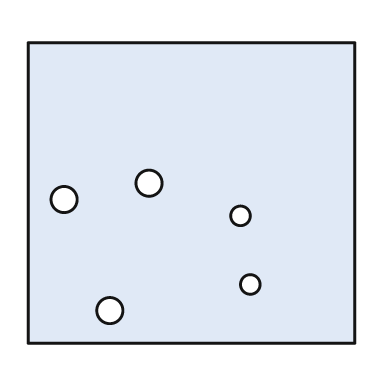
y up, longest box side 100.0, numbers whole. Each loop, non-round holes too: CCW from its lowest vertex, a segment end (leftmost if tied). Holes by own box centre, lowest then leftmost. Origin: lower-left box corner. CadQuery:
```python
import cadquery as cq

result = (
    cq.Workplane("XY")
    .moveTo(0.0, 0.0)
    .lineTo(100.0, 0.0)
    .lineTo(100.0, 92.0)
    .lineTo(0.0, 92.0)
    .close()
    .moveTo(25.0, 10.0)
    .circle(4.0)
    .moveTo(68.0, 18.0)
    .circle(3.0)
    .moveTo(65.0, 39.0)
    .circle(3.0)
    .moveTo(11.0, 44.0)
    .circle(4.0)
    .moveTo(37.0, 49.0)
    .circle(4.0)
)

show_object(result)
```